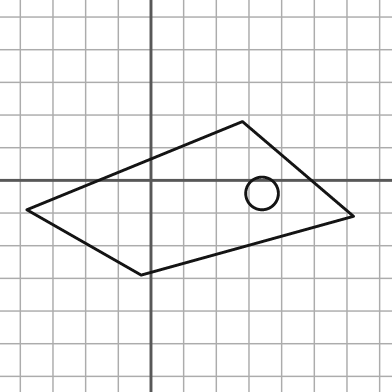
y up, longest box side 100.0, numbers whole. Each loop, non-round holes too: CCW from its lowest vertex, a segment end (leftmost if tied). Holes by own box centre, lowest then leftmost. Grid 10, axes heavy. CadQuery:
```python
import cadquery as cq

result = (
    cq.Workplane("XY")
    .moveTo(-3.0, -29.0)
    .lineTo(62.0, -11.0)
    .lineTo(28.0, 18.0)
    .lineTo(-38.0, -9.0)
    .close()
    .moveTo(34.0, -4.0)
    .circle(5.0)
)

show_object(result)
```